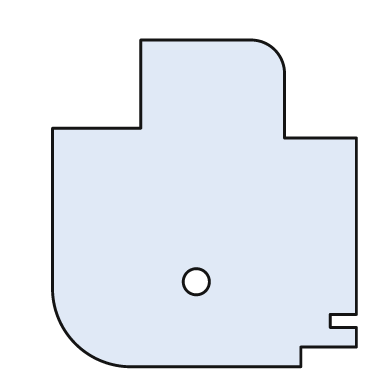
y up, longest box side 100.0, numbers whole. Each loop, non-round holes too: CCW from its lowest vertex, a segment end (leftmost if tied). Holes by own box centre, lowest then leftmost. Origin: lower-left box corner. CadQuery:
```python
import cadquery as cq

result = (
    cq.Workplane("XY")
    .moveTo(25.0, 0.0)
    .lineTo(76.0, 0.0)
    .lineTo(76.0, 6.0)
    .lineTo(93.0, 6.0)
    .lineTo(93.0, 12.0)
    .lineTo(85.0, 12.0)
    .lineTo(85.0, 16.0)
    .lineTo(93.0, 16.0)
    .lineTo(93.0, 70.0)
    .lineTo(71.0, 70.0)
    .lineTo(71.0, 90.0)
    .threePointArc((68.0, 97.0), (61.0, 100.0))
    .lineTo(27.0, 100.0)
    .lineTo(27.0, 73.0)
    .lineTo(0.0, 73.0)
    .lineTo(0.0, 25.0)
    .threePointArc((7.0, 7.0), (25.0, 0.0))
    .close()
    .moveTo(44.0, 26.0)
    .circle(4.0)
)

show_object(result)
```